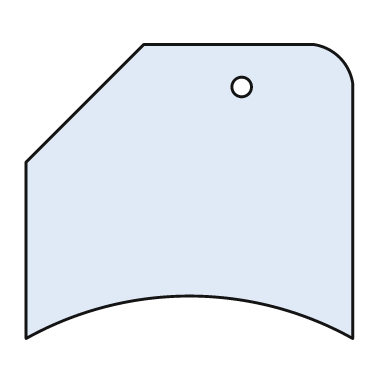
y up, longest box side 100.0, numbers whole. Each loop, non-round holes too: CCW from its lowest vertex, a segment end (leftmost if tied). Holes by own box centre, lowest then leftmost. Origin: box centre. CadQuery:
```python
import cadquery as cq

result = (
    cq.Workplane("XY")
    .moveTo(-50.0, -45.0)
    .threePointArc((0.0, -32.0), (50.0, -45.0))
    .lineTo(50.0, 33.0)
    .threePointArc((46.0, 41.0), (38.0, 45.0))
    .lineTo(-14.0, 45.0)
    .lineTo(-50.0, 9.0)
    .close()
    .moveTo(16.0, 32.0)
    .circle(3.0)
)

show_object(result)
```